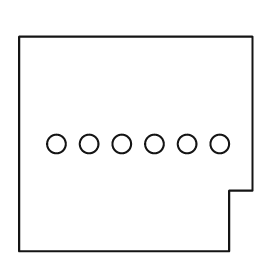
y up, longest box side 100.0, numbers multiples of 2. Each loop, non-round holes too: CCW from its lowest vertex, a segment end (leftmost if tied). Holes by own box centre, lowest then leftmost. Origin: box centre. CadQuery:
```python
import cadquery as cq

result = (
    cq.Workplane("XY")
    .moveTo(-50.0, -46.0)
    .lineTo(40.0, -46.0)
    .lineTo(40.0, -20.0)
    .lineTo(50.0, -20.0)
    .lineTo(50.0, 46.0)
    .lineTo(-50.0, 46.0)
    .close()
    .moveTo(-34.0, 0.0)
    .circle(4.0)
    .moveTo(-20.0, 0.0)
    .circle(4.0)
    .moveTo(-6.0, 0.0)
    .circle(4.0)
    .moveTo(8.0, 0.0)
    .circle(4.0)
    .moveTo(22.0, 0.0)
    .circle(4.0)
    .moveTo(36.0, 0.0)
    .circle(4.0)
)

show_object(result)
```